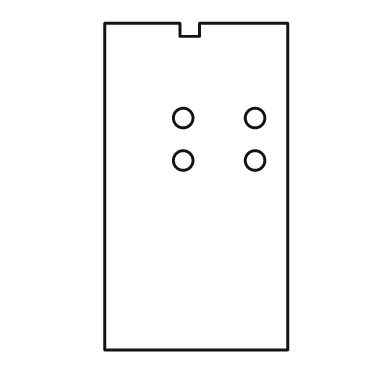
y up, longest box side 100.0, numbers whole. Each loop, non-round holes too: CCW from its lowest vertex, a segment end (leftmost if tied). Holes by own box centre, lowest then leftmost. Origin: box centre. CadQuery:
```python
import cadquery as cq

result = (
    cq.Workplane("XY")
    .moveTo(-28.0, -50.0)
    .lineTo(28.0, -50.0)
    .lineTo(28.0, 50.0)
    .lineTo(1.0, 50.0)
    .lineTo(1.0, 46.0)
    .lineTo(-5.0, 46.0)
    .lineTo(-5.0, 50.0)
    .lineTo(-28.0, 50.0)
    .close()
    .moveTo(-4.0, 8.0)
    .circle(3.0)
    .moveTo(18.0, 8.0)
    .circle(3.0)
    .moveTo(-4.0, 21.0)
    .circle(3.0)
    .moveTo(18.0, 21.0)
    .circle(3.0)
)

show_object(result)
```